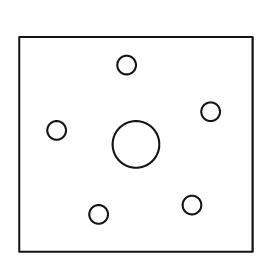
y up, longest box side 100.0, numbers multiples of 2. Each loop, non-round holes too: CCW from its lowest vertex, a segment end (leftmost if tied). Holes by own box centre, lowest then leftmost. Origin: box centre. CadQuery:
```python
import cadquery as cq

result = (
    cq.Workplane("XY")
    .moveTo(-50.0, -46.0)
    .lineTo(50.0, -46.0)
    .lineTo(50.0, 46.0)
    .lineTo(-50.0, 46.0)
    .close()
    .moveTo(-16.0, -30.0)
    .circle(4.0)
    .moveTo(24.0, -26.0)
    .circle(4.0)
    .moveTo(0.0, 0.0)
    .circle(10.0)
    .moveTo(-34.0, 6.0)
    .circle(4.0)
    .moveTo(32.0, 14.0)
    .circle(4.0)
    .moveTo(-4.0, 34.0)
    .circle(4.0)
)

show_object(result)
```